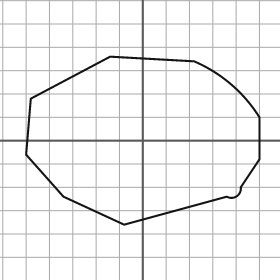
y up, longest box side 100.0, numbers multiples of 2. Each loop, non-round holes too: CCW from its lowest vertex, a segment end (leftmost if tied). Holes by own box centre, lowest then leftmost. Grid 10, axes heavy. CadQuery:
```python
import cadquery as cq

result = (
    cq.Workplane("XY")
    .moveTo(-8.0, -36.0)
    .lineTo(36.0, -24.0)
    .threePointArc((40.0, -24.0), (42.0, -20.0))
    .lineTo(50.0, -8.0)
    .lineTo(50.0, 10.0)
    .threePointArc((38.0, 24.0), (22.0, 34.0))
    .lineTo(-14.0, 36.0)
    .lineTo(-48.0, 18.0)
    .lineTo(-50.0, -6.0)
    .lineTo(-34.0, -24.0)
    .close()
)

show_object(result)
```